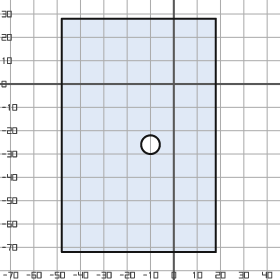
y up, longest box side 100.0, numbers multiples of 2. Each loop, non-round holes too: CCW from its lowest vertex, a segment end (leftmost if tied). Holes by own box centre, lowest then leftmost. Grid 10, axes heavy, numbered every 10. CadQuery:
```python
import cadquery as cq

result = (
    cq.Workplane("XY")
    .moveTo(-48.0, -72.0)
    .lineTo(18.0, -72.0)
    .lineTo(18.0, 28.0)
    .lineTo(-48.0, 28.0)
    .close()
    .moveTo(-10.0, -26.0)
    .circle(4.0)
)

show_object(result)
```